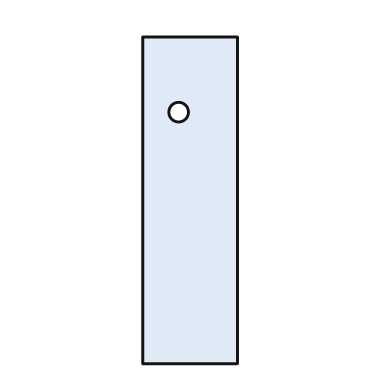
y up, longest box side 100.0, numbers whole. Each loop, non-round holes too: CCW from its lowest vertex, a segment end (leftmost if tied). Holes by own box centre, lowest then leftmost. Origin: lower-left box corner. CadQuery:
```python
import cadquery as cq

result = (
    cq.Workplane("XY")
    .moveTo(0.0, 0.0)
    .lineTo(29.0, 0.0)
    .lineTo(29.0, 100.0)
    .lineTo(0.0, 100.0)
    .close()
    .moveTo(11.0, 77.0)
    .circle(3.0)
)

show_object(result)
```